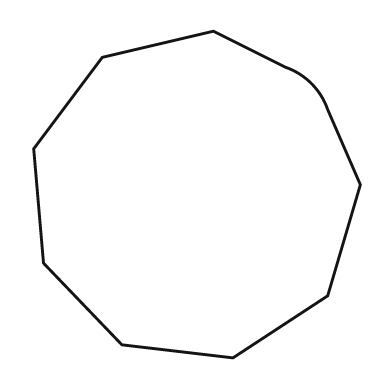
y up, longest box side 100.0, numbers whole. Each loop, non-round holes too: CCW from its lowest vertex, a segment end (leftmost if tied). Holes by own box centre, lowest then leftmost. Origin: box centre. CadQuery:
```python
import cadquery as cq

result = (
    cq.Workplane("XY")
    .moveTo(11.0, -50.0)
    .lineTo(40.0, -31.0)
    .lineTo(50.0, 3.0)
    .lineTo(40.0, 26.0)
    .threePointArc((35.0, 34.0), (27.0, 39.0))
    .lineTo(5.0, 50.0)
    .lineTo(-29.0, 42.0)
    .lineTo(-50.0, 14.0)
    .lineTo(-47.0, -21.0)
    .lineTo(-23.0, -46.0)
    .close()
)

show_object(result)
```